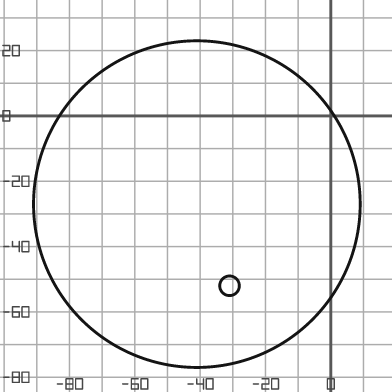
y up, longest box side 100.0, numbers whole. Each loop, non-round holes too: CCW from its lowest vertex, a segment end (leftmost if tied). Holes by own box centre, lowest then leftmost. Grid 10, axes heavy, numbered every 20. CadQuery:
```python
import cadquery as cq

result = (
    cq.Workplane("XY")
    .moveTo(-41.0, -27.0)
    .circle(50.0)
    .moveTo(-31.0, -52.0)
    .circle(3.0)
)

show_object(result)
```